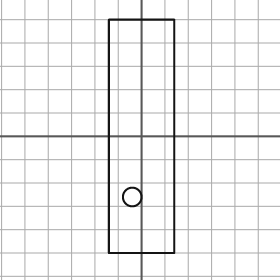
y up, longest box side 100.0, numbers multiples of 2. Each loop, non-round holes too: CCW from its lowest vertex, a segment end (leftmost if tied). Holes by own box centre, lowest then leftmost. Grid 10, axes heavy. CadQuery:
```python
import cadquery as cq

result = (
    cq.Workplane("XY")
    .moveTo(-14.0, -50.0)
    .lineTo(14.0, -50.0)
    .lineTo(14.0, 50.0)
    .lineTo(-14.0, 50.0)
    .close()
    .moveTo(-4.0, -26.0)
    .circle(4.0)
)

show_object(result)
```